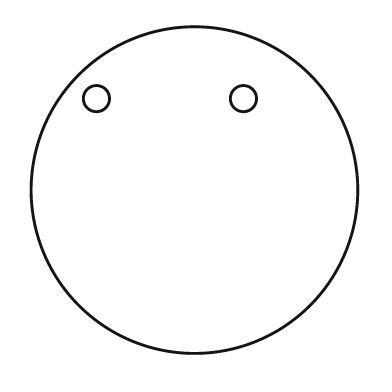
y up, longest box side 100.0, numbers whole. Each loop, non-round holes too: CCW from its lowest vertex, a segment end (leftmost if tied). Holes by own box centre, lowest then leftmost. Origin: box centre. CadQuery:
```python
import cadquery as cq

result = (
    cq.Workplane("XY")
    .moveTo(0.0, 0.0)
    .circle(50.0)
    .moveTo(-30.0, 28.0)
    .circle(4.0)
    .moveTo(15.0, 28.0)
    .circle(4.0)
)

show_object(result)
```